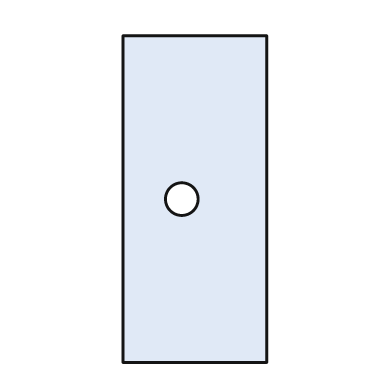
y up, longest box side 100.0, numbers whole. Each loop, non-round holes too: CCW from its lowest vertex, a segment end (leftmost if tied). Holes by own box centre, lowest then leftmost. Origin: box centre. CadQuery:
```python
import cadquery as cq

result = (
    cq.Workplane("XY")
    .moveTo(-22.0, -50.0)
    .lineTo(22.0, -50.0)
    .lineTo(22.0, 50.0)
    .lineTo(-22.0, 50.0)
    .close()
    .moveTo(-4.0, 0.0)
    .circle(5.0)
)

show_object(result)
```